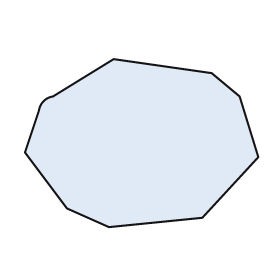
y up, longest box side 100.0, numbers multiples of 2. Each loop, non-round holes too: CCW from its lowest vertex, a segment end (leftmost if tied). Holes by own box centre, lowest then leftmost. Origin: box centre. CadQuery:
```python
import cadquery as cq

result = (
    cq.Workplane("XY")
    .moveTo(-14.0, -36.0)
    .lineTo(26.0, -32.0)
    .lineTo(50.0, -6.0)
    .lineTo(42.0, 20.0)
    .lineTo(30.0, 30.0)
    .lineTo(-12.0, 36.0)
    .lineTo(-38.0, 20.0)
    .threePointArc((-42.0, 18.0), (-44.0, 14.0))
    .lineTo(-50.0, -4.0)
    .lineTo(-32.0, -28.0)
    .close()
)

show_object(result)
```